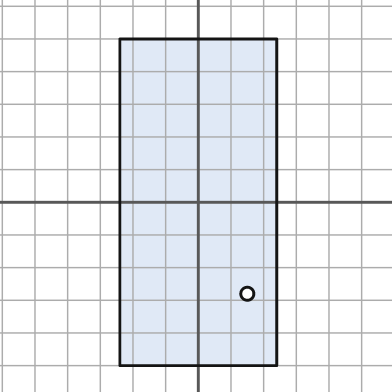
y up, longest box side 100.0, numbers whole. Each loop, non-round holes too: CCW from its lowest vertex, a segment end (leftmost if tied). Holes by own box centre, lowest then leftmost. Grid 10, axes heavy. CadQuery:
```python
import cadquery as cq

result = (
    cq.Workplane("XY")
    .moveTo(-24.0, -50.0)
    .lineTo(24.0, -50.0)
    .lineTo(24.0, 50.0)
    .lineTo(-24.0, 50.0)
    .close()
    .moveTo(15.0, -28.0)
    .circle(2.0)
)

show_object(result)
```